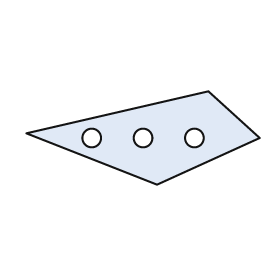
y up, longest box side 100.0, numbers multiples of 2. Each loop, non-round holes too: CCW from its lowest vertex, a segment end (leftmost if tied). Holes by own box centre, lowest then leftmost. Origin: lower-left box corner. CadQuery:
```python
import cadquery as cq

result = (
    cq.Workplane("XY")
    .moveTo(56.0, 0.0)
    .lineTo(100.0, 20.0)
    .lineTo(78.0, 40.0)
    .lineTo(0.0, 22.0)
    .close()
    .moveTo(28.0, 20.0)
    .circle(4.0)
    .moveTo(50.0, 20.0)
    .circle(4.0)
    .moveTo(72.0, 20.0)
    .circle(4.0)
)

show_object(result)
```